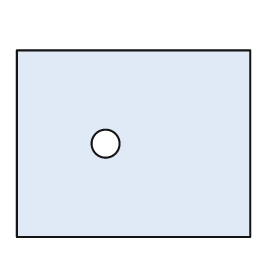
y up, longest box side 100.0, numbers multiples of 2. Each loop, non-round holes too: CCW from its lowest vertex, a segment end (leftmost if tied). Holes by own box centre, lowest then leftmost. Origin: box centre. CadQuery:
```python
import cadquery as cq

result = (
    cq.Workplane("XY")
    .moveTo(-50.0, -40.0)
    .lineTo(50.0, -40.0)
    .lineTo(50.0, 40.0)
    .lineTo(-50.0, 40.0)
    .close()
    .moveTo(-12.0, 0.0)
    .circle(6.0)
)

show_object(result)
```